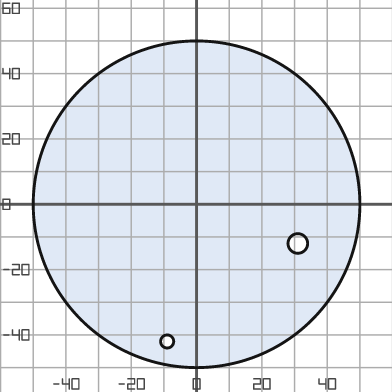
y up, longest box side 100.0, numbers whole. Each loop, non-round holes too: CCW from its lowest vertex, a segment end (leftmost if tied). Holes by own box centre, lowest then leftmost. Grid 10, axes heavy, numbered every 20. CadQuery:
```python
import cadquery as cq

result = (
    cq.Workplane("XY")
    .moveTo(0.0, 0.0)
    .circle(50.0)
    .moveTo(-9.0, -42.0)
    .circle(2.0)
    .moveTo(31.0, -12.0)
    .circle(3.0)
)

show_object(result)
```